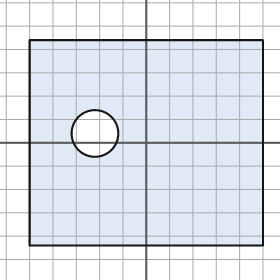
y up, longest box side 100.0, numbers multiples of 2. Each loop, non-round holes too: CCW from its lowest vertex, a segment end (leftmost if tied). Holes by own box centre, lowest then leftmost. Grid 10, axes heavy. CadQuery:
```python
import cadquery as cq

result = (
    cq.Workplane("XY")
    .moveTo(-50.0, -44.0)
    .lineTo(50.0, -44.0)
    .lineTo(50.0, 44.0)
    .lineTo(-50.0, 44.0)
    .close()
    .moveTo(-22.0, 4.0)
    .circle(10.0)
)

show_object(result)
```